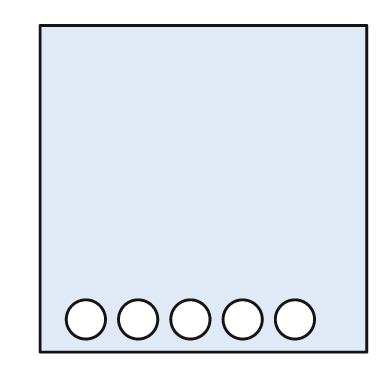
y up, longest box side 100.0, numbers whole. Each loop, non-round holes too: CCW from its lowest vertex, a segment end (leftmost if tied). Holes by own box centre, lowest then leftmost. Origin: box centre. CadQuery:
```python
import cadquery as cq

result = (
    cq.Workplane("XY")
    .moveTo(-50.0, -50.0)
    .lineTo(50.0, -50.0)
    .lineTo(50.0, 50.0)
    .lineTo(-50.0, 50.0)
    .close()
    .moveTo(-36.0, -40.0)
    .circle(6.0)
    .moveTo(-20.0, -40.0)
    .circle(6.0)
    .moveTo(-4.0, -40.0)
    .circle(6.0)
    .moveTo(12.0, -40.0)
    .circle(6.0)
    .moveTo(28.0, -40.0)
    .circle(6.0)
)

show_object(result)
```